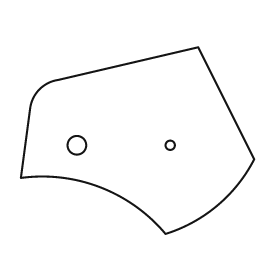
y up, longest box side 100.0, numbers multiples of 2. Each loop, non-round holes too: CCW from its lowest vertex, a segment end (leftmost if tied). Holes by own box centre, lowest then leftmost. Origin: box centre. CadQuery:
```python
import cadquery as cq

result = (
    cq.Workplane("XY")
    .moveTo(12.0, -40.0)
    .threePointArc((34.0, -28.0), (50.0, -8.0))
    .lineTo(26.0, 40.0)
    .lineTo(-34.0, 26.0)
    .threePointArc((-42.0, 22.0), (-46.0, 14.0))
    .lineTo(-50.0, -16.0)
    .threePointArc((-16.0, -20.0), (12.0, -40.0))
    .close()
    .moveTo(-26.0, -2.0)
    .circle(4.0)
    .moveTo(14.0, -2.0)
    .circle(2.0)
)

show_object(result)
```